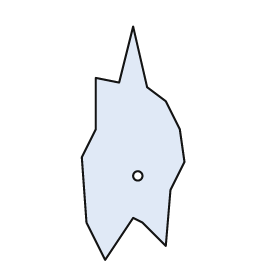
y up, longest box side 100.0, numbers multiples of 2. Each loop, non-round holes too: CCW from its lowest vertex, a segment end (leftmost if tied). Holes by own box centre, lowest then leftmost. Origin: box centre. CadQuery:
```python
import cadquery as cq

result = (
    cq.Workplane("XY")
    .moveTo(-12.0, -50.0)
    .lineTo(0.0, -32.0)
    .lineTo(4.0, -34.0)
    .lineTo(14.0, -44.0)
    .lineTo(16.0, -20.0)
    .lineTo(22.0, -8.0)
    .lineTo(20.0, 6.0)
    .lineTo(14.0, 18.0)
    .lineTo(6.0, 24.0)
    .lineTo(0.0, 50.0)
    .lineTo(-6.0, 26.0)
    .lineTo(-16.0, 28.0)
    .lineTo(-16.0, 6.0)
    .lineTo(-22.0, -6.0)
    .lineTo(-20.0, -34.0)
    .close()
    .moveTo(2.0, -14.0)
    .circle(2.0)
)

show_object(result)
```